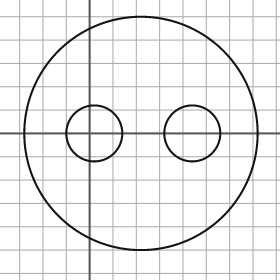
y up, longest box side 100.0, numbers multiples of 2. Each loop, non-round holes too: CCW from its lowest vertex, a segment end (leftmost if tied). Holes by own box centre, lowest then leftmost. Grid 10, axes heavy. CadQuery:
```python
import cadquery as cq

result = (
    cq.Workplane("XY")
    .moveTo(22.0, 0.0)
    .circle(50.0)
    .moveTo(2.0, 0.0)
    .circle(12.0)
    .moveTo(44.0, 0.0)
    .circle(12.0)
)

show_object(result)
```